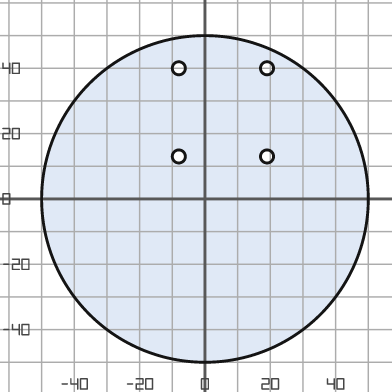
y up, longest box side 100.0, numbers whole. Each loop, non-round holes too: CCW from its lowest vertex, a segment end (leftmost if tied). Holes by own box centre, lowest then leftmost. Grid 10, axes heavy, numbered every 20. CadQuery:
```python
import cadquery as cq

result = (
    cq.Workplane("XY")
    .moveTo(0.0, 0.0)
    .circle(50.0)
    .moveTo(-8.0, 13.0)
    .circle(2.0)
    .moveTo(19.0, 13.0)
    .circle(2.0)
    .moveTo(-8.0, 40.0)
    .circle(2.0)
    .moveTo(19.0, 40.0)
    .circle(2.0)
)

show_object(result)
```